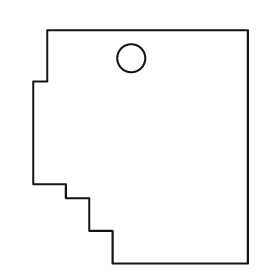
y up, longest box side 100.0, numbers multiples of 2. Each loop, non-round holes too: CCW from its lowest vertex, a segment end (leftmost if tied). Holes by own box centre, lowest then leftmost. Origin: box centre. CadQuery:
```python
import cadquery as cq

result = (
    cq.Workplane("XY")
    .moveTo(-12.0, -50.0)
    .lineTo(46.0, -50.0)
    .lineTo(46.0, 50.0)
    .lineTo(-40.0, 50.0)
    .lineTo(-40.0, 28.0)
    .lineTo(-46.0, 28.0)
    .lineTo(-46.0, -16.0)
    .lineTo(-32.0, -16.0)
    .lineTo(-32.0, -22.0)
    .lineTo(-22.0, -22.0)
    .lineTo(-22.0, -36.0)
    .lineTo(-12.0, -36.0)
    .close()
    .moveTo(-4.0, 38.0)
    .circle(6.0)
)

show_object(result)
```